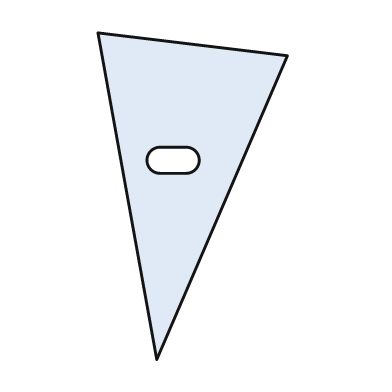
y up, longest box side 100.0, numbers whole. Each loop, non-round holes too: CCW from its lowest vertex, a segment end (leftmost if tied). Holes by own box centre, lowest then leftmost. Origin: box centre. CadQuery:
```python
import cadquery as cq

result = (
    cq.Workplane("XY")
    .moveTo(-11.0, -50.0)
    .lineTo(29.0, 43.0)
    .lineTo(-29.0, 50.0)
    .close()
    .moveTo(-10.0, 7.0)
    .lineTo(-2.0, 7.0)
    .threePointArc((2.0, 11.0), (-2.0, 15.0))
    .lineTo(-10.0, 15.0)
    .threePointArc((-14.0, 11.0), (-10.0, 7.0))
    .close()
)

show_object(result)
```